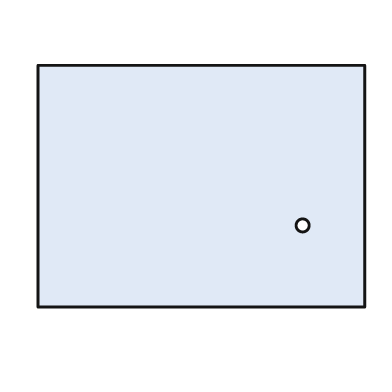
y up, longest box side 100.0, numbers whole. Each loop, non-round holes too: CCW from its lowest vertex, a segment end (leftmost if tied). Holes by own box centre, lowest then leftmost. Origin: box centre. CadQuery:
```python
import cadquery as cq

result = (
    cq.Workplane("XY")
    .moveTo(-50.0, -37.0)
    .lineTo(50.0, -37.0)
    .lineTo(50.0, 37.0)
    .lineTo(-50.0, 37.0)
    .close()
    .moveTo(31.0, -12.0)
    .circle(2.0)
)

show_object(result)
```